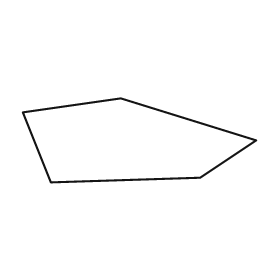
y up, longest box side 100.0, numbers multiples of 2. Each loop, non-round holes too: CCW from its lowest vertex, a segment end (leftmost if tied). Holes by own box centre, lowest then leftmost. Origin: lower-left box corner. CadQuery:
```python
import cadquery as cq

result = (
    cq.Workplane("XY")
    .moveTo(12.0, 0.0)
    .lineTo(76.0, 2.0)
    .lineTo(100.0, 18.0)
    .lineTo(42.0, 36.0)
    .lineTo(0.0, 30.0)
    .close()
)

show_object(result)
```